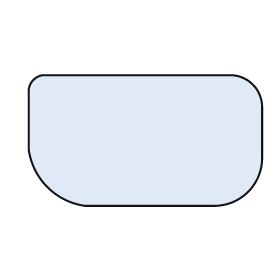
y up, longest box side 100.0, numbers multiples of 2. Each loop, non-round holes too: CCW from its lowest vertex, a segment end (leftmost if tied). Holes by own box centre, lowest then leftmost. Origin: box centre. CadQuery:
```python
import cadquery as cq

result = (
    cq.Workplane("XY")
    .moveTo(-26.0, -28.0)
    .lineTo(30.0, -28.0)
    .threePointArc((44.0, -22.0), (50.0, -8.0))
    .lineTo(50.0, 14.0)
    .threePointArc((46.0, 24.0), (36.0, 28.0))
    .lineTo(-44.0, 28.0)
    .threePointArc((-48.0, 26.0), (-50.0, 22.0))
    .lineTo(-50.0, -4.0)
    .threePointArc((-42.0, -20.0), (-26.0, -28.0))
    .close()
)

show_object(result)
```